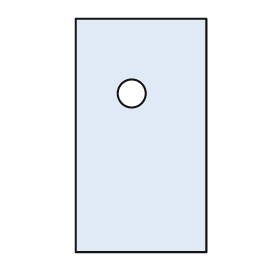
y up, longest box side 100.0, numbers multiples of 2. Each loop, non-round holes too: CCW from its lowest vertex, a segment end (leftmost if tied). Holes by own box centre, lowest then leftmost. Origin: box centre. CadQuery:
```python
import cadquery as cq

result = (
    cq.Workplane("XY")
    .moveTo(-28.0, -50.0)
    .lineTo(28.0, -50.0)
    .lineTo(28.0, 50.0)
    .lineTo(-28.0, 50.0)
    .close()
    .moveTo(-4.0, 18.0)
    .circle(6.0)
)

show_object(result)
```